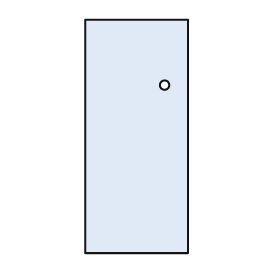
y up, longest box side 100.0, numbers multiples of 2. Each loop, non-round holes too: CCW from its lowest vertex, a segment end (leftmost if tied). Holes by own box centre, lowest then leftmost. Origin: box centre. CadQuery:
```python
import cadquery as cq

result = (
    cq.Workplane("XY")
    .moveTo(-22.0, -50.0)
    .lineTo(22.0, -50.0)
    .lineTo(22.0, 50.0)
    .lineTo(-22.0, 50.0)
    .close()
    .moveTo(12.0, 22.0)
    .circle(2.0)
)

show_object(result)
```